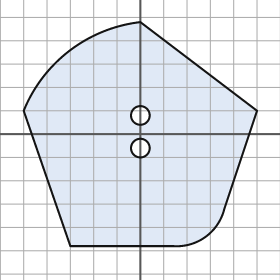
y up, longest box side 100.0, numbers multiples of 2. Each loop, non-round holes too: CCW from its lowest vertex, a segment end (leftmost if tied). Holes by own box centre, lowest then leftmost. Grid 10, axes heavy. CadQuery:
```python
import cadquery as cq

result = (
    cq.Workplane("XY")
    .moveTo(-30.0, -48.0)
    .lineTo(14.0, -48.0)
    .threePointArc((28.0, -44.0), (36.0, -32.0))
    .lineTo(50.0, 10.0)
    .lineTo(0.0, 48.0)
    .threePointArc((-30.0, 36.0), (-50.0, 10.0))
    .close()
    .moveTo(0.0, -6.0)
    .circle(4.0)
    .moveTo(0.0, 8.0)
    .circle(4.0)
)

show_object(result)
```